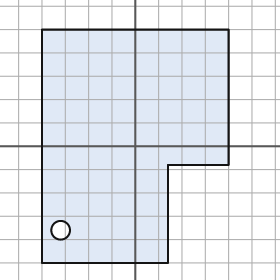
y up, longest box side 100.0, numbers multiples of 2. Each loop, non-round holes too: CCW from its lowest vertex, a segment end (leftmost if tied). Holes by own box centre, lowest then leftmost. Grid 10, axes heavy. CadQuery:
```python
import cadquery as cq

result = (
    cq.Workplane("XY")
    .moveTo(-40.0, -50.0)
    .lineTo(14.0, -50.0)
    .lineTo(14.0, -8.0)
    .lineTo(40.0, -8.0)
    .lineTo(40.0, 50.0)
    .lineTo(-40.0, 50.0)
    .close()
    .moveTo(-32.0, -36.0)
    .circle(4.0)
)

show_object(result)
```